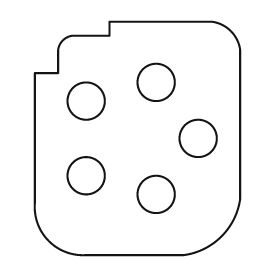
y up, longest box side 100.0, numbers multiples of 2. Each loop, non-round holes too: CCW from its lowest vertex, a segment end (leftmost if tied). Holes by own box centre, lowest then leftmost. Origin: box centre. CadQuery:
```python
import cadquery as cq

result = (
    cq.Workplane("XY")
    .moveTo(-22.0, -50.0)
    .lineTo(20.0, -50.0)
    .threePointArc((36.0, -42.0), (44.0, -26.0))
    .lineTo(44.0, 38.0)
    .threePointArc((40.0, 46.0), (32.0, 50.0))
    .lineTo(-12.0, 50.0)
    .lineTo(-12.0, 44.0)
    .lineTo(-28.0, 44.0)
    .threePointArc((-32.0, 42.0), (-34.0, 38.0))
    .lineTo(-34.0, 28.0)
    .lineTo(-44.0, 28.0)
    .lineTo(-44.0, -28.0)
    .threePointArc((-38.0, -44.0), (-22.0, -50.0))
    .close()
    .moveTo(8.0, -24.0)
    .circle(8.0)
    .moveTo(-22.0, -16.0)
    .circle(8.0)
    .moveTo(26.0, 0.0)
    .circle(8.0)
    .moveTo(-22.0, 16.0)
    .circle(8.0)
    .moveTo(8.0, 24.0)
    .circle(8.0)
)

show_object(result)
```